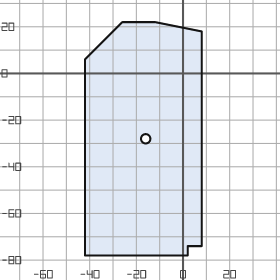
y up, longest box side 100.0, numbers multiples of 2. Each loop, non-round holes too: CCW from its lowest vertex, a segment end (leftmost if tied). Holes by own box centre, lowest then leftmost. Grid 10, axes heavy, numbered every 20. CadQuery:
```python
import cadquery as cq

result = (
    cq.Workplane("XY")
    .moveTo(-42.0, -78.0)
    .lineTo(2.0, -78.0)
    .lineTo(2.0, -74.0)
    .lineTo(8.0, -74.0)
    .lineTo(8.0, 18.0)
    .lineTo(-12.0, 22.0)
    .lineTo(-26.0, 22.0)
    .lineTo(-42.0, 6.0)
    .close()
    .moveTo(-16.0, -28.0)
    .circle(2.0)
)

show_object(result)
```